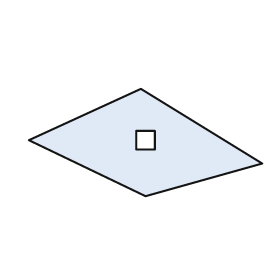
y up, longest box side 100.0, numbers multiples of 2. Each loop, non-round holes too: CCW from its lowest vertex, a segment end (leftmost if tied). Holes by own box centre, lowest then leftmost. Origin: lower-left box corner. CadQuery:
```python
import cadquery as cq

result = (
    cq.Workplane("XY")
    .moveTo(50.0, 0.0)
    .lineTo(100.0, 14.0)
    .lineTo(48.0, 46.0)
    .lineTo(0.0, 24.0)
    .close()
    .moveTo(46.0, 20.0)
    .lineTo(54.0, 20.0)
    .lineTo(54.0, 28.0)
    .lineTo(46.0, 28.0)
    .close()
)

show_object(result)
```